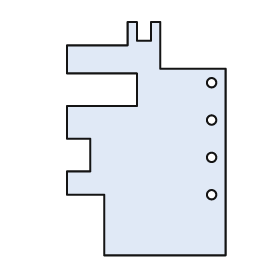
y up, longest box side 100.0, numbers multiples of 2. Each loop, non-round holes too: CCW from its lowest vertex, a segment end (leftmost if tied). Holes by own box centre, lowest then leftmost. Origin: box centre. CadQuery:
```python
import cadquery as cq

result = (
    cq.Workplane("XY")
    .moveTo(-18.0, -50.0)
    .lineTo(34.0, -50.0)
    .lineTo(34.0, 30.0)
    .lineTo(6.0, 30.0)
    .lineTo(6.0, 50.0)
    .lineTo(2.0, 50.0)
    .lineTo(2.0, 42.0)
    .lineTo(-4.0, 42.0)
    .lineTo(-4.0, 50.0)
    .lineTo(-8.0, 50.0)
    .lineTo(-8.0, 40.0)
    .lineTo(-34.0, 40.0)
    .lineTo(-34.0, 28.0)
    .lineTo(-4.0, 28.0)
    .lineTo(-4.0, 14.0)
    .lineTo(-34.0, 14.0)
    .lineTo(-34.0, 0.0)
    .lineTo(-24.0, 0.0)
    .lineTo(-24.0, -14.0)
    .lineTo(-34.0, -14.0)
    .lineTo(-34.0, -24.0)
    .lineTo(-18.0, -24.0)
    .close()
    .moveTo(28.0, -24.0)
    .circle(2.0)
    .moveTo(28.0, -8.0)
    .circle(2.0)
    .moveTo(28.0, 8.0)
    .circle(2.0)
    .moveTo(28.0, 24.0)
    .circle(2.0)
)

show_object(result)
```